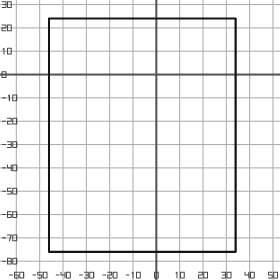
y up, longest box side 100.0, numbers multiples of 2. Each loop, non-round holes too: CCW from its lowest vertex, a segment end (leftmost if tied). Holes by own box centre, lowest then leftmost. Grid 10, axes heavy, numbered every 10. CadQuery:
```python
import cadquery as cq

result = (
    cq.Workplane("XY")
    .moveTo(-46.0, -76.0)
    .lineTo(34.0, -76.0)
    .lineTo(34.0, 24.0)
    .lineTo(-46.0, 24.0)
    .close()
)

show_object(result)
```